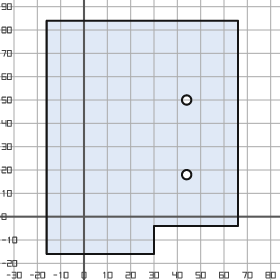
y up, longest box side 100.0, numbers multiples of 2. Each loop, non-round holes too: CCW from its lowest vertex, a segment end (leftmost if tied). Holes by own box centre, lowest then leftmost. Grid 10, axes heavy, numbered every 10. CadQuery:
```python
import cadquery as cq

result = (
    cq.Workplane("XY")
    .moveTo(-16.0, -16.0)
    .lineTo(30.0, -16.0)
    .lineTo(30.0, -4.0)
    .lineTo(66.0, -4.0)
    .lineTo(66.0, 84.0)
    .lineTo(-16.0, 84.0)
    .close()
    .moveTo(44.0, 18.0)
    .circle(2.0)
    .moveTo(44.0, 50.0)
    .circle(2.0)
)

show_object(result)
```